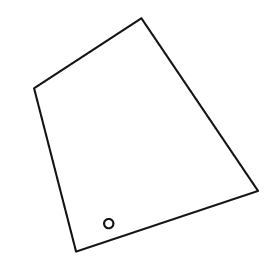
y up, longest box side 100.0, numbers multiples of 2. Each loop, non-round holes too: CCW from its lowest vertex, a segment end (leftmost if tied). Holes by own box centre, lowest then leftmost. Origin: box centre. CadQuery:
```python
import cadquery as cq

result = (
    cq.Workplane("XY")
    .moveTo(-30.0, -50.0)
    .lineTo(48.0, -24.0)
    .lineTo(-2.0, 50.0)
    .lineTo(-48.0, 20.0)
    .close()
    .moveTo(-16.0, -38.0)
    .circle(2.0)
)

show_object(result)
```